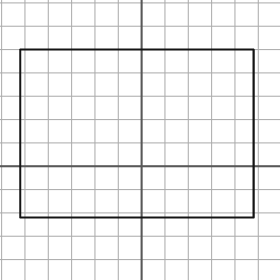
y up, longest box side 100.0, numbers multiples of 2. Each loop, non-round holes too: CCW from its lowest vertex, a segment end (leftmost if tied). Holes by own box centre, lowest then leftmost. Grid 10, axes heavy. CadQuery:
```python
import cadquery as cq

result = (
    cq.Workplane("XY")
    .moveTo(-52.0, -22.0)
    .lineTo(48.0, -22.0)
    .lineTo(48.0, 50.0)
    .lineTo(-52.0, 50.0)
    .close()
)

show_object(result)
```